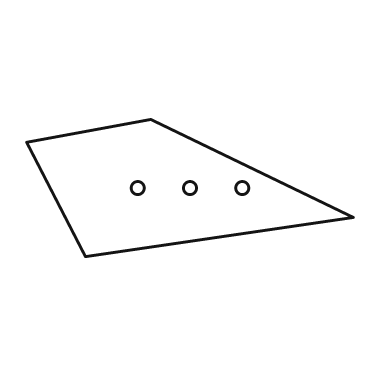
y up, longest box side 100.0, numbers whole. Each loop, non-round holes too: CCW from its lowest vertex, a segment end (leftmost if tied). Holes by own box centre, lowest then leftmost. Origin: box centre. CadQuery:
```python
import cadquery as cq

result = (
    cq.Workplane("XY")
    .moveTo(-32.0, -21.0)
    .lineTo(50.0, -9.0)
    .lineTo(-12.0, 21.0)
    .lineTo(-50.0, 14.0)
    .close()
    .moveTo(-16.0, 0.0)
    .circle(2.0)
    .moveTo(0.0, 0.0)
    .circle(2.0)
    .moveTo(16.0, 0.0)
    .circle(2.0)
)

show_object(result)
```